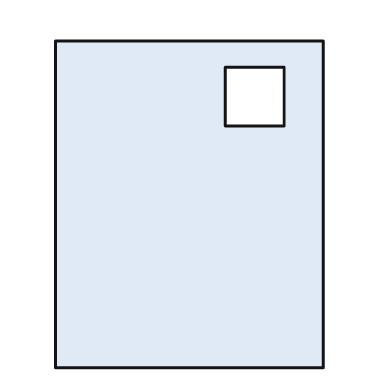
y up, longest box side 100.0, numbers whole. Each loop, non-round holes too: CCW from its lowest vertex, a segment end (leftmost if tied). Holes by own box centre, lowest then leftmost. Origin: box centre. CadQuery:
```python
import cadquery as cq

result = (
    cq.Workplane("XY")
    .moveTo(-41.0, -50.0)
    .lineTo(41.0, -50.0)
    .lineTo(41.0, 50.0)
    .lineTo(-41.0, 50.0)
    .close()
    .moveTo(11.0, 24.0)
    .lineTo(29.0, 24.0)
    .lineTo(29.0, 42.0)
    .lineTo(11.0, 42.0)
    .close()
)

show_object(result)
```